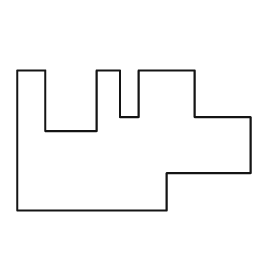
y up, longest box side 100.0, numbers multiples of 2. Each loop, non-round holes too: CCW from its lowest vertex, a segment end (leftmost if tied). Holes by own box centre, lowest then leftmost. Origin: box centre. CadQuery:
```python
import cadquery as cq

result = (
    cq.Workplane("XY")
    .moveTo(-50.0, -30.0)
    .lineTo(14.0, -30.0)
    .lineTo(14.0, -14.0)
    .lineTo(50.0, -14.0)
    .lineTo(50.0, 10.0)
    .lineTo(26.0, 10.0)
    .lineTo(26.0, 30.0)
    .lineTo(2.0, 30.0)
    .lineTo(2.0, 10.0)
    .lineTo(-6.0, 10.0)
    .lineTo(-6.0, 30.0)
    .lineTo(-16.0, 30.0)
    .lineTo(-16.0, 4.0)
    .lineTo(-38.0, 4.0)
    .lineTo(-38.0, 30.0)
    .lineTo(-50.0, 30.0)
    .close()
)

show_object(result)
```